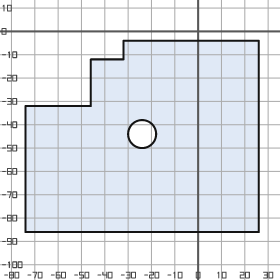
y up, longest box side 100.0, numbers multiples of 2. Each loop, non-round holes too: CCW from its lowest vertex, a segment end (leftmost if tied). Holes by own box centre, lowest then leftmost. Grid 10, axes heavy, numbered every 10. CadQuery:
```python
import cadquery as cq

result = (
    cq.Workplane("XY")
    .moveTo(-74.0, -86.0)
    .lineTo(26.0, -86.0)
    .lineTo(26.0, -4.0)
    .lineTo(-32.0, -4.0)
    .lineTo(-32.0, -12.0)
    .lineTo(-46.0, -12.0)
    .lineTo(-46.0, -32.0)
    .lineTo(-74.0, -32.0)
    .close()
    .moveTo(-24.0, -44.0)
    .circle(6.0)
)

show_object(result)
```